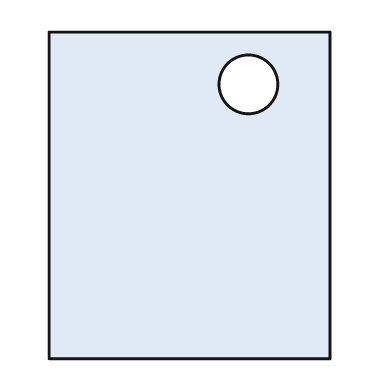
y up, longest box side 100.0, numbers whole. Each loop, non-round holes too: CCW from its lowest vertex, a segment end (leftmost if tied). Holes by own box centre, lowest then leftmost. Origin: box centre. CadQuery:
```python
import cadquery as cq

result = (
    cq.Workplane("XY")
    .moveTo(-43.0, -50.0)
    .lineTo(43.0, -50.0)
    .lineTo(43.0, 50.0)
    .lineTo(-43.0, 50.0)
    .close()
    .moveTo(18.0, 34.0)
    .circle(9.0)
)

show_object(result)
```